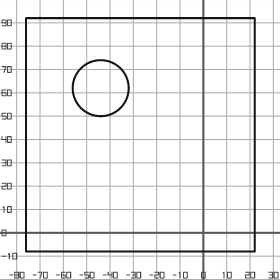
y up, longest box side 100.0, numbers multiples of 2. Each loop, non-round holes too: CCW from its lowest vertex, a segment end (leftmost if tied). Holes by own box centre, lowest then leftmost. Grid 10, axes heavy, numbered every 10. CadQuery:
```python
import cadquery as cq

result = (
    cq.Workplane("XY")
    .moveTo(-76.0, -8.0)
    .lineTo(22.0, -8.0)
    .lineTo(22.0, 92.0)
    .lineTo(-76.0, 92.0)
    .close()
    .moveTo(-44.0, 62.0)
    .circle(12.0)
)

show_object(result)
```